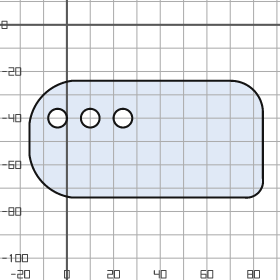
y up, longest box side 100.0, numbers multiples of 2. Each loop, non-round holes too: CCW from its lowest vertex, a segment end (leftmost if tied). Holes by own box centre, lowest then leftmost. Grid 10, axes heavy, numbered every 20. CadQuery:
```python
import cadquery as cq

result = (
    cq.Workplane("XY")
    .moveTo(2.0, -74.0)
    .lineTo(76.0, -74.0)
    .threePointArc((82.0, -72.0), (84.0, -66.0))
    .lineTo(84.0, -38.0)
    .threePointArc((80.0, -28.0), (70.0, -24.0))
    .lineTo(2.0, -24.0)
    .threePointArc((-10.0, -30.0), (-16.0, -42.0))
    .lineTo(-16.0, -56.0)
    .threePointArc((-10.0, -68.0), (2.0, -74.0))
    .close()
    .moveTo(-4.0, -40.0)
    .circle(4.0)
    .moveTo(10.0, -40.0)
    .circle(4.0)
    .moveTo(24.0, -40.0)
    .circle(4.0)
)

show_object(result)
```